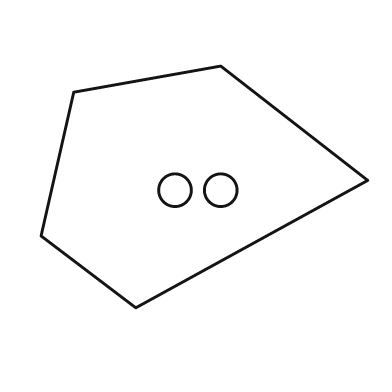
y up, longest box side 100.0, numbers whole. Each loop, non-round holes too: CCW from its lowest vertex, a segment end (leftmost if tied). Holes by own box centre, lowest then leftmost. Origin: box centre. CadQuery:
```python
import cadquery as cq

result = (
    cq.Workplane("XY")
    .moveTo(-21.0, -37.0)
    .lineTo(50.0, 2.0)
    .lineTo(5.0, 37.0)
    .lineTo(-40.0, 29.0)
    .lineTo(-50.0, -15.0)
    .close()
    .moveTo(-9.0, -1.0)
    .circle(5.0)
    .moveTo(5.0, -1.0)
    .circle(5.0)
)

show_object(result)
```